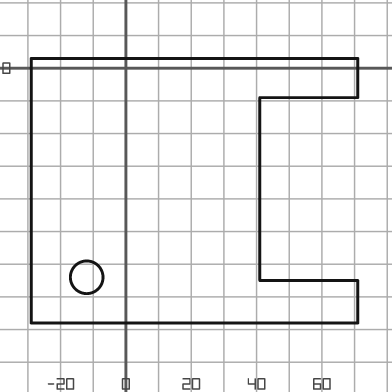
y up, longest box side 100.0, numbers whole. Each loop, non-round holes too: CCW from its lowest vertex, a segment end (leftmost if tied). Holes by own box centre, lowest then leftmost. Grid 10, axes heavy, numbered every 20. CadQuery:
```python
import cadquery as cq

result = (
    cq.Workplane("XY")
    .moveTo(-29.0, -78.0)
    .lineTo(71.0, -78.0)
    .lineTo(71.0, -65.0)
    .lineTo(41.0, -65.0)
    .lineTo(41.0, -9.0)
    .lineTo(71.0, -9.0)
    .lineTo(71.0, 3.0)
    .lineTo(-29.0, 3.0)
    .close()
    .moveTo(-12.0, -64.0)
    .circle(5.0)
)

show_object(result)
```